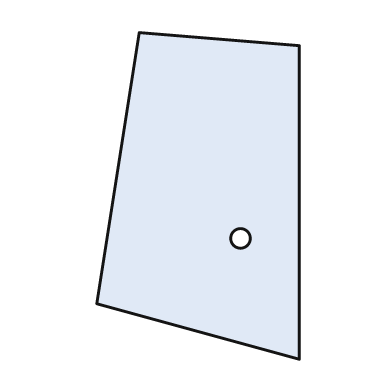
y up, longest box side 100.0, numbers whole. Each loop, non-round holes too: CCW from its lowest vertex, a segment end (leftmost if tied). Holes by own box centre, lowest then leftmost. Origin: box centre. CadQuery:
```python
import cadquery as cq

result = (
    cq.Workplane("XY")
    .moveTo(31.0, -50.0)
    .lineTo(31.0, 46.0)
    .lineTo(-18.0, 50.0)
    .lineTo(-31.0, -33.0)
    .close()
    .moveTo(13.0, -13.0)
    .circle(3.0)
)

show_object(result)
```